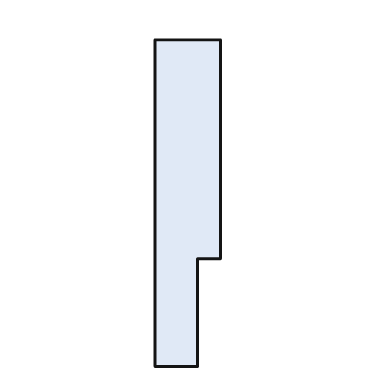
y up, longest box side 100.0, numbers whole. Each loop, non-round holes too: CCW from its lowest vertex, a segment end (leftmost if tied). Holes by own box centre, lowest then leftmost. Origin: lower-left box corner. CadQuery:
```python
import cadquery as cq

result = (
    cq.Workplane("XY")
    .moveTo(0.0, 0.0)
    .lineTo(13.0, 0.0)
    .lineTo(13.0, 33.0)
    .lineTo(20.0, 33.0)
    .lineTo(20.0, 100.0)
    .lineTo(0.0, 100.0)
    .close()
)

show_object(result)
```